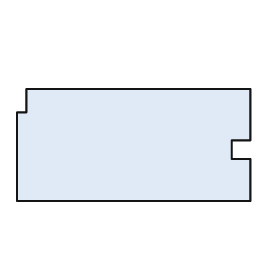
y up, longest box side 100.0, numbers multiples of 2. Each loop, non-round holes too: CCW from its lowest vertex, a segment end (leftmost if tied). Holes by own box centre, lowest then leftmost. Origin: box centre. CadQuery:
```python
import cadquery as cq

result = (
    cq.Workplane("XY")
    .moveTo(-50.0, -24.0)
    .lineTo(50.0, -24.0)
    .lineTo(50.0, -6.0)
    .lineTo(42.0, -6.0)
    .lineTo(42.0, 2.0)
    .lineTo(50.0, 2.0)
    .lineTo(50.0, 24.0)
    .lineTo(-46.0, 24.0)
    .lineTo(-46.0, 14.0)
    .lineTo(-50.0, 14.0)
    .close()
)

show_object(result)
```